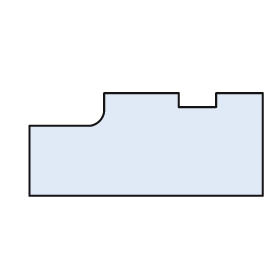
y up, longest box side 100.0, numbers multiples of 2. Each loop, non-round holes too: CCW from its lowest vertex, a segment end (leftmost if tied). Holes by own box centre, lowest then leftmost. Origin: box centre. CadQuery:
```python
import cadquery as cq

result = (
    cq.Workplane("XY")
    .moveTo(-50.0, -22.0)
    .lineTo(50.0, -22.0)
    .lineTo(50.0, 22.0)
    .lineTo(30.0, 22.0)
    .lineTo(30.0, 16.0)
    .lineTo(14.0, 16.0)
    .lineTo(14.0, 22.0)
    .lineTo(-18.0, 22.0)
    .lineTo(-18.0, 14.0)
    .threePointArc((-20.0, 10.0), (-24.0, 8.0))
    .lineTo(-50.0, 8.0)
    .close()
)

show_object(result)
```